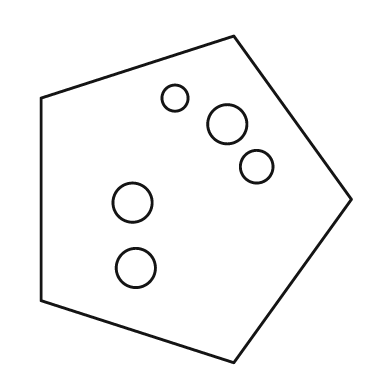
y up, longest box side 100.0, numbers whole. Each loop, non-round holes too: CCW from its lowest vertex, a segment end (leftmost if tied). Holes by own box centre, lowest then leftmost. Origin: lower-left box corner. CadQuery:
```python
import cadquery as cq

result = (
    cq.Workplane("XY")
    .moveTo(59.0, 0.0)
    .lineTo(95.0, 50.0)
    .lineTo(59.0, 100.0)
    .lineTo(0.0, 81.0)
    .lineTo(0.0, 19.0)
    .close()
    .moveTo(29.0, 29.0)
    .circle(6.0)
    .moveTo(28.0, 49.0)
    .circle(6.0)
    .moveTo(66.0, 60.0)
    .circle(5.0)
    .moveTo(57.0, 73.0)
    .circle(6.0)
    .moveTo(41.0, 81.0)
    .circle(4.0)
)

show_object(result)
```